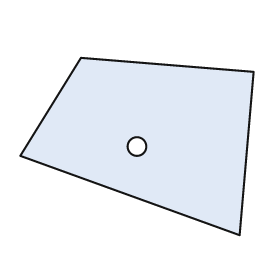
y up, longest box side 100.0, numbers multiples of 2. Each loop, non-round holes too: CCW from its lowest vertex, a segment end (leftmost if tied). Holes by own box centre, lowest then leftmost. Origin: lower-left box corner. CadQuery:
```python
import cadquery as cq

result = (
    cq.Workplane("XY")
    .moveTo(94.0, 0.0)
    .lineTo(100.0, 70.0)
    .lineTo(26.0, 76.0)
    .lineTo(0.0, 34.0)
    .close()
    .moveTo(50.0, 38.0)
    .circle(4.0)
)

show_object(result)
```